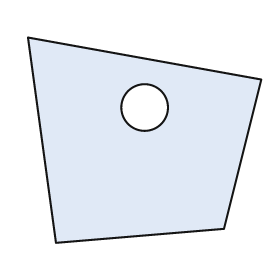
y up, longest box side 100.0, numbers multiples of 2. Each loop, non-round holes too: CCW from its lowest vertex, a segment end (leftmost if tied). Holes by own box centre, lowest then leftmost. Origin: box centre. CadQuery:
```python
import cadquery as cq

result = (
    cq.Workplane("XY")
    .moveTo(-38.0, -44.0)
    .lineTo(34.0, -38.0)
    .lineTo(50.0, 26.0)
    .lineTo(-50.0, 44.0)
    .close()
    .moveTo(0.0, 14.0)
    .circle(10.0)
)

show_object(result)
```